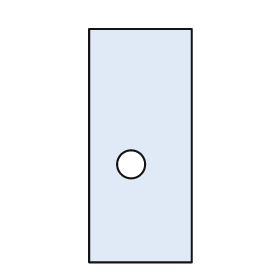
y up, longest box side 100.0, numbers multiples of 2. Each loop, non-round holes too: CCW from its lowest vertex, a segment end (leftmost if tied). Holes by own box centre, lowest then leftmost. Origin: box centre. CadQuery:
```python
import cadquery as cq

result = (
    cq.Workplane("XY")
    .moveTo(-22.0, -50.0)
    .lineTo(22.0, -50.0)
    .lineTo(22.0, 50.0)
    .lineTo(-22.0, 50.0)
    .close()
    .moveTo(-4.0, -8.0)
    .circle(6.0)
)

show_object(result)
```